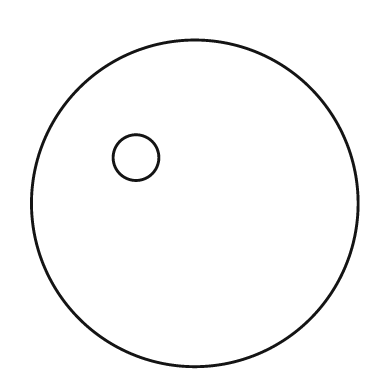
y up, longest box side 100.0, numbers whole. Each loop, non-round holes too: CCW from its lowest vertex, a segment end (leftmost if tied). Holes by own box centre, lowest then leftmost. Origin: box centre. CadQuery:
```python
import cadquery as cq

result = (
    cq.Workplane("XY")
    .moveTo(0.0, 0.0)
    .circle(50.0)
    .moveTo(-18.0, 14.0)
    .circle(7.0)
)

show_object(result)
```